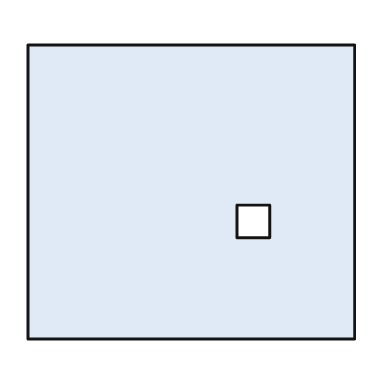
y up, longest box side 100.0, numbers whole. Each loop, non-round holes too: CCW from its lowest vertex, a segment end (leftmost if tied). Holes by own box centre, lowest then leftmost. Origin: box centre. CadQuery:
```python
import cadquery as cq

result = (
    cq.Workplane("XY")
    .moveTo(-50.0, -45.0)
    .lineTo(50.0, -45.0)
    .lineTo(50.0, 45.0)
    .lineTo(-50.0, 45.0)
    .close()
    .moveTo(14.0, -14.0)
    .lineTo(24.0, -14.0)
    .lineTo(24.0, -4.0)
    .lineTo(14.0, -4.0)
    .close()
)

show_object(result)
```